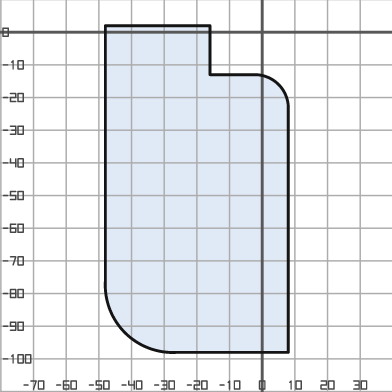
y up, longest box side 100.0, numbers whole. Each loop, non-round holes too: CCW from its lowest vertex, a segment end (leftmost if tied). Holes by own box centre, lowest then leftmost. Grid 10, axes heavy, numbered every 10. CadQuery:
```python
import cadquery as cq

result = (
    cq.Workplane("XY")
    .moveTo(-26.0, -98.0)
    .lineTo(8.0, -98.0)
    .lineTo(8.0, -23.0)
    .threePointArc((5.0, -16.0), (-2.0, -13.0))
    .lineTo(-16.0, -13.0)
    .lineTo(-16.0, 2.0)
    .lineTo(-48.0, 2.0)
    .lineTo(-48.0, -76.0)
    .threePointArc((-42.0, -92.0), (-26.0, -98.0))
    .close()
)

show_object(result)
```